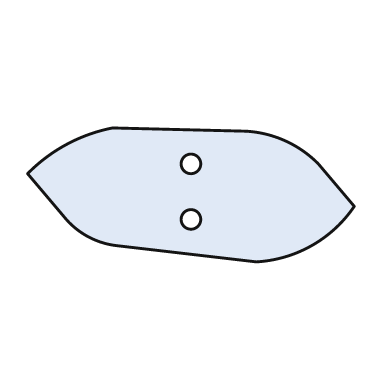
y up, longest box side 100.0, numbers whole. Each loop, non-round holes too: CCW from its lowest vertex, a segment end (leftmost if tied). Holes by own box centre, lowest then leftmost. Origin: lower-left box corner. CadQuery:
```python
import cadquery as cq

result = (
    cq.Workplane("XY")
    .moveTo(70.0, 0.0)
    .threePointArc((87.0, 5.0), (100.0, 17.0))
    .lineTo(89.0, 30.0)
    .threePointArc((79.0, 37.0), (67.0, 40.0))
    .lineTo(26.0, 41.0)
    .threePointArc((12.0, 36.0), (0.0, 27.0))
    .lineTo(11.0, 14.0)
    .threePointArc((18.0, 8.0), (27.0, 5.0))
    .close()
    .moveTo(50.0, 13.0)
    .circle(3.0)
    .moveTo(50.0, 30.0)
    .circle(3.0)
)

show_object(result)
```